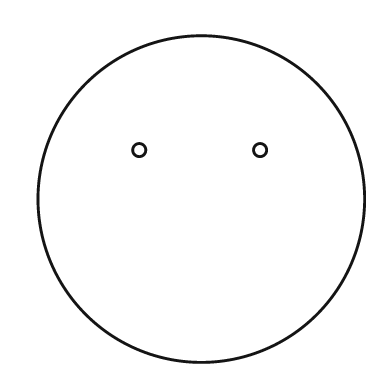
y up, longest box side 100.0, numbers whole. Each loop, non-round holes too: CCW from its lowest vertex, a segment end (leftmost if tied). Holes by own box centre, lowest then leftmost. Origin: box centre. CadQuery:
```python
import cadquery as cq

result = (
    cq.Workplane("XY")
    .moveTo(0.0, 0.0)
    .circle(50.0)
    .moveTo(-19.0, 15.0)
    .circle(2.0)
    .moveTo(18.0, 15.0)
    .circle(2.0)
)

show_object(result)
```